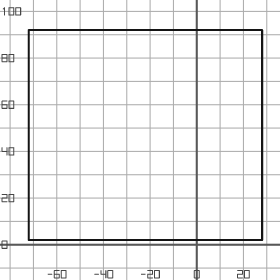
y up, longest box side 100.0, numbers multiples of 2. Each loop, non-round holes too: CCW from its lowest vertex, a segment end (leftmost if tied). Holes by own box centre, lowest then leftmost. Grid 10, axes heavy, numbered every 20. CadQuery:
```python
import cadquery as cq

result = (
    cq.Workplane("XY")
    .moveTo(-72.0, 2.0)
    .lineTo(28.0, 2.0)
    .lineTo(28.0, 92.0)
    .lineTo(-72.0, 92.0)
    .close()
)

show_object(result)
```